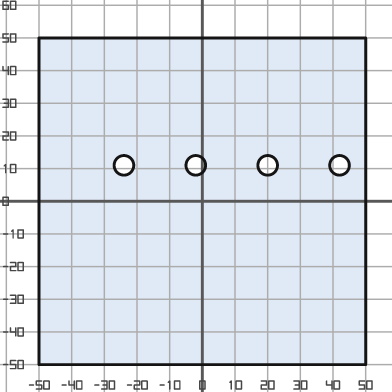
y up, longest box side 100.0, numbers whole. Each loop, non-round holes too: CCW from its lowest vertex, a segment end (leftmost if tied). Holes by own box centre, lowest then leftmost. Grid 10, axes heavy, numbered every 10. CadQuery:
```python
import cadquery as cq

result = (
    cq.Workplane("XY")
    .moveTo(-50.0, -50.0)
    .lineTo(50.0, -50.0)
    .lineTo(50.0, 50.0)
    .lineTo(-50.0, 50.0)
    .close()
    .moveTo(-24.0, 11.0)
    .circle(3.0)
    .moveTo(-2.0, 11.0)
    .circle(3.0)
    .moveTo(20.0, 11.0)
    .circle(3.0)
    .moveTo(42.0, 11.0)
    .circle(3.0)
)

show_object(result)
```